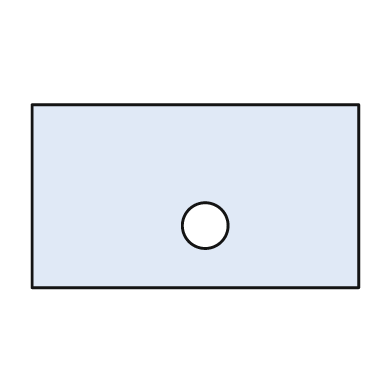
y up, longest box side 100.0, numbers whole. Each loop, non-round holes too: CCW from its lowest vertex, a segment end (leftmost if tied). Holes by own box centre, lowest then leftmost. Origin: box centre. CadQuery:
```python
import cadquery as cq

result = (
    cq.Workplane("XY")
    .moveTo(-50.0, -28.0)
    .lineTo(50.0, -28.0)
    .lineTo(50.0, 28.0)
    .lineTo(-50.0, 28.0)
    .close()
    .moveTo(3.0, -9.0)
    .circle(7.0)
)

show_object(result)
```